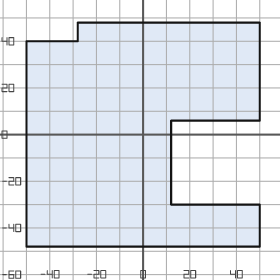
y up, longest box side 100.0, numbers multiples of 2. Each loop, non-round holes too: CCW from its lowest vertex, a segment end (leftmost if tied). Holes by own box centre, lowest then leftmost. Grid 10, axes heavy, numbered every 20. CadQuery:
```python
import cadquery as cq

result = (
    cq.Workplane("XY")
    .moveTo(-50.0, -48.0)
    .lineTo(50.0, -48.0)
    .lineTo(50.0, -30.0)
    .lineTo(12.0, -30.0)
    .lineTo(12.0, 6.0)
    .lineTo(50.0, 6.0)
    .lineTo(50.0, 48.0)
    .lineTo(-28.0, 48.0)
    .lineTo(-28.0, 40.0)
    .lineTo(-50.0, 40.0)
    .close()
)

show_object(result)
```